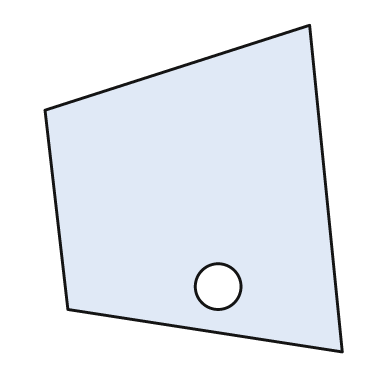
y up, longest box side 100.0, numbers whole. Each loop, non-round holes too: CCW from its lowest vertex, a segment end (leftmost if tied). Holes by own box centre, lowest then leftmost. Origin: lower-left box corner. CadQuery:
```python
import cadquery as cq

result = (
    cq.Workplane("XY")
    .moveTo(91.0, 0.0)
    .lineTo(81.0, 100.0)
    .lineTo(0.0, 74.0)
    .lineTo(7.0, 13.0)
    .close()
    .moveTo(53.0, 20.0)
    .circle(7.0)
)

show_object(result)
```